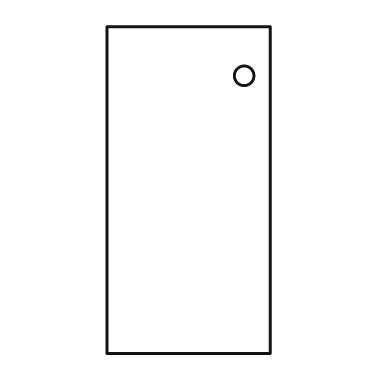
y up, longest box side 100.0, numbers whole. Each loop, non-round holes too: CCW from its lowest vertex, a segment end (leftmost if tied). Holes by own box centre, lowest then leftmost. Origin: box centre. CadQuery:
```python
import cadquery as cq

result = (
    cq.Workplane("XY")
    .moveTo(-25.0, -50.0)
    .lineTo(25.0, -50.0)
    .lineTo(25.0, 50.0)
    .lineTo(-25.0, 50.0)
    .close()
    .moveTo(17.0, 35.0)
    .circle(3.0)
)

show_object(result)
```